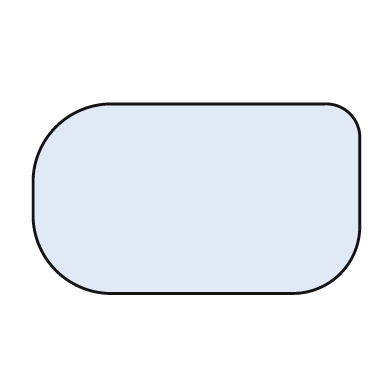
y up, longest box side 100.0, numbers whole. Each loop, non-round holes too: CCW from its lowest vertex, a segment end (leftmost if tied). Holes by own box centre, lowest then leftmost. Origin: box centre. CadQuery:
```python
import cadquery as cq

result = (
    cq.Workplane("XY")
    .moveTo(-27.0, -29.0)
    .lineTo(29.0, -29.0)
    .threePointArc((44.0, -23.0), (50.0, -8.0))
    .lineTo(50.0, 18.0)
    .threePointArc((47.0, 26.0), (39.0, 29.0))
    .lineTo(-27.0, 29.0)
    .threePointArc((-43.0, 22.0), (-50.0, 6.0))
    .lineTo(-50.0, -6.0)
    .threePointArc((-43.0, -22.0), (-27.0, -29.0))
    .close()
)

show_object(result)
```